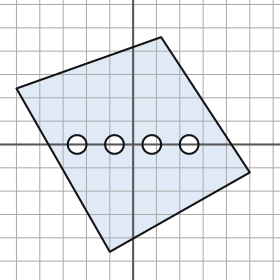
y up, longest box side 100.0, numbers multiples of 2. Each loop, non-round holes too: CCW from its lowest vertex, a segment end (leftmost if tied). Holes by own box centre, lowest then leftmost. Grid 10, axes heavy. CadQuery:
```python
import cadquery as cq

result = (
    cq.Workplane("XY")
    .moveTo(-10.0, -46.0)
    .lineTo(50.0, -12.0)
    .lineTo(12.0, 46.0)
    .lineTo(-50.0, 24.0)
    .close()
    .moveTo(-24.0, 0.0)
    .circle(4.0)
    .moveTo(-8.0, 0.0)
    .circle(4.0)
    .moveTo(8.0, 0.0)
    .circle(4.0)
    .moveTo(24.0, 0.0)
    .circle(4.0)
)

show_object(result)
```